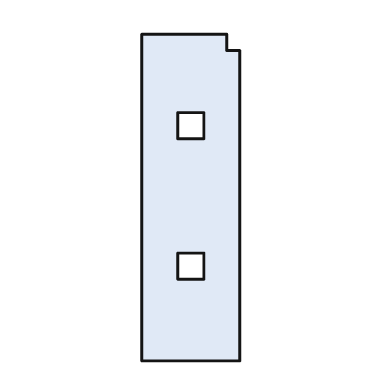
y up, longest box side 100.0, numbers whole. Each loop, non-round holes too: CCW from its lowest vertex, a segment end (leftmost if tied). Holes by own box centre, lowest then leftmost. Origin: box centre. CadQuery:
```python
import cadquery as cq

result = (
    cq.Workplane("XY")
    .moveTo(-15.0, -50.0)
    .lineTo(15.0, -50.0)
    .lineTo(15.0, 45.0)
    .lineTo(11.0, 45.0)
    .lineTo(11.0, 50.0)
    .lineTo(-15.0, 50.0)
    .close()
    .moveTo(-4.0, -25.0)
    .lineTo(4.0, -25.0)
    .lineTo(4.0, -17.0)
    .lineTo(-4.0, -17.0)
    .close()
    .moveTo(-4.0, 18.0)
    .lineTo(4.0, 18.0)
    .lineTo(4.0, 26.0)
    .lineTo(-4.0, 26.0)
    .close()
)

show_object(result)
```